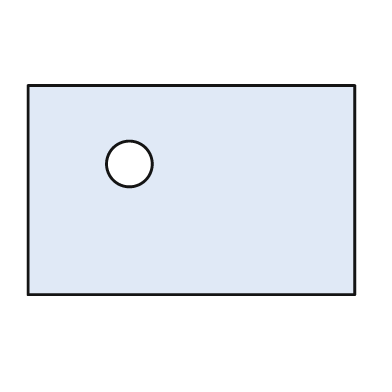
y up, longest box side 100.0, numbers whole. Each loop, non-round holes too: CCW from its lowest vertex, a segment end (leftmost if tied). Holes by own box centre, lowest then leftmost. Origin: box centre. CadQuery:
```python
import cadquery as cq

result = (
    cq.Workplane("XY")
    .moveTo(-50.0, -32.0)
    .lineTo(50.0, -32.0)
    .lineTo(50.0, 32.0)
    .lineTo(-50.0, 32.0)
    .close()
    .moveTo(-19.0, 8.0)
    .circle(7.0)
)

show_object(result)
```